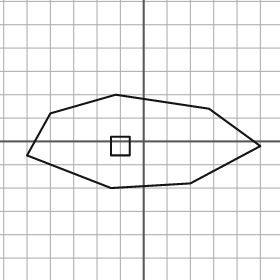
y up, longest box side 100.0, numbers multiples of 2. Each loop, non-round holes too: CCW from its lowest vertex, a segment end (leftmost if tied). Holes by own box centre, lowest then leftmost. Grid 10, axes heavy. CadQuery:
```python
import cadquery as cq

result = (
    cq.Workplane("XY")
    .moveTo(-14.0, -20.0)
    .lineTo(20.0, -18.0)
    .lineTo(50.0, -2.0)
    .lineTo(28.0, 14.0)
    .lineTo(-12.0, 20.0)
    .lineTo(-40.0, 12.0)
    .lineTo(-50.0, -6.0)
    .close()
    .moveTo(-14.0, -6.0)
    .lineTo(-6.0, -6.0)
    .lineTo(-6.0, 2.0)
    .lineTo(-14.0, 2.0)
    .close()
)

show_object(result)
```